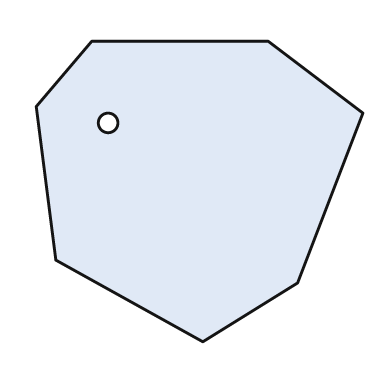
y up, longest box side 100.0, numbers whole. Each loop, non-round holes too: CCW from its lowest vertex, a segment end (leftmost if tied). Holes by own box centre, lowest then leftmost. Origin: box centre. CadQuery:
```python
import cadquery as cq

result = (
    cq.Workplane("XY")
    .moveTo(1.0, -46.0)
    .lineTo(30.0, -28.0)
    .lineTo(50.0, 24.0)
    .lineTo(21.0, 46.0)
    .lineTo(-33.0, 46.0)
    .lineTo(-50.0, 26.0)
    .lineTo(-44.0, -21.0)
    .close()
    .moveTo(-28.0, 21.0)
    .circle(3.0)
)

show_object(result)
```